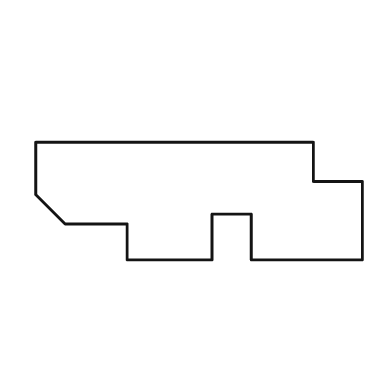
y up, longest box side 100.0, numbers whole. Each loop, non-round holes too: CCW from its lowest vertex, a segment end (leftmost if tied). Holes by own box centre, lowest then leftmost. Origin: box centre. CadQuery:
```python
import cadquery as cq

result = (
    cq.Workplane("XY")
    .moveTo(-22.0, -18.0)
    .lineTo(4.0, -18.0)
    .lineTo(4.0, -4.0)
    .lineTo(16.0, -4.0)
    .lineTo(16.0, -18.0)
    .lineTo(50.0, -18.0)
    .lineTo(50.0, 6.0)
    .lineTo(35.0, 6.0)
    .lineTo(35.0, 18.0)
    .lineTo(-50.0, 18.0)
    .lineTo(-50.0, 2.0)
    .lineTo(-41.0, -7.0)
    .lineTo(-22.0, -7.0)
    .close()
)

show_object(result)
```